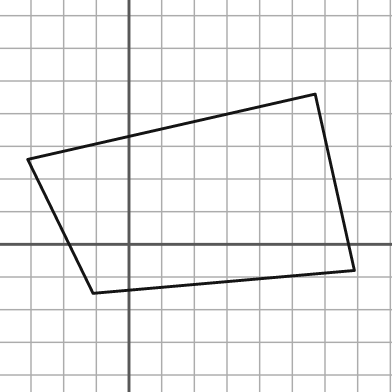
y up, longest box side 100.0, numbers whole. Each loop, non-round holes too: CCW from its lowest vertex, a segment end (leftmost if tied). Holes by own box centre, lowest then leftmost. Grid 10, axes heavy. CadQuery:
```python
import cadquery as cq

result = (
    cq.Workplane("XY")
    .moveTo(-11.0, -15.0)
    .lineTo(69.0, -8.0)
    .lineTo(57.0, 46.0)
    .lineTo(-31.0, 26.0)
    .close()
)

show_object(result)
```